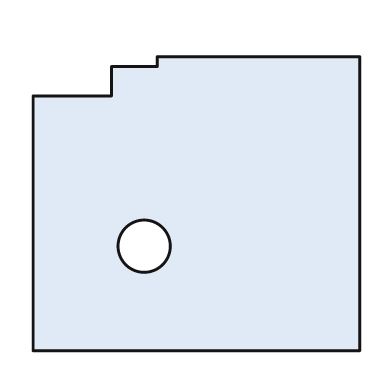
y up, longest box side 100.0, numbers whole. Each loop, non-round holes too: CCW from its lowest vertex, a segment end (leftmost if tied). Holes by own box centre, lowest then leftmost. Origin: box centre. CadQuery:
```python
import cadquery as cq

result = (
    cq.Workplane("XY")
    .moveTo(-50.0, -45.0)
    .lineTo(50.0, -45.0)
    .lineTo(50.0, 45.0)
    .lineTo(-12.0, 45.0)
    .lineTo(-12.0, 42.0)
    .lineTo(-26.0, 42.0)
    .lineTo(-26.0, 33.0)
    .lineTo(-50.0, 33.0)
    .close()
    .moveTo(-16.0, -13.0)
    .circle(8.0)
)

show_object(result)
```